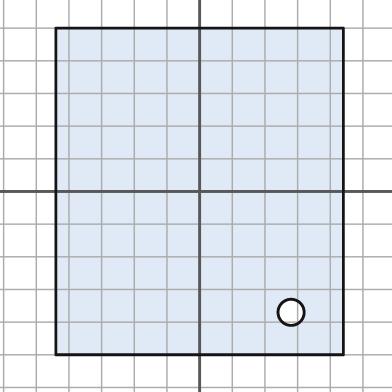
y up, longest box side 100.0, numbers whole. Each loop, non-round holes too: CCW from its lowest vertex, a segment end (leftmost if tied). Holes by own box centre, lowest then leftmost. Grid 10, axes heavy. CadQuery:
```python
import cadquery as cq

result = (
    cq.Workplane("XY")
    .moveTo(-44.0, -50.0)
    .lineTo(44.0, -50.0)
    .lineTo(44.0, 50.0)
    .lineTo(-44.0, 50.0)
    .close()
    .moveTo(28.0, -37.0)
    .circle(4.0)
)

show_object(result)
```